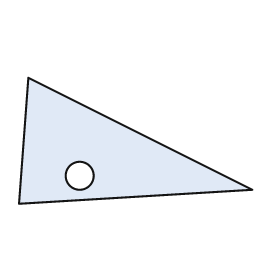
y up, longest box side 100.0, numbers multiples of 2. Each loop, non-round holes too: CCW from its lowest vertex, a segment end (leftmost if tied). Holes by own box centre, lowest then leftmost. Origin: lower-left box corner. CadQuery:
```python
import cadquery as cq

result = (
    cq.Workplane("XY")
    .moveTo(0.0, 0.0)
    .lineTo(100.0, 6.0)
    .lineTo(4.0, 54.0)
    .close()
    .moveTo(26.0, 12.0)
    .circle(6.0)
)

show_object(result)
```